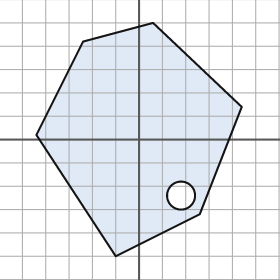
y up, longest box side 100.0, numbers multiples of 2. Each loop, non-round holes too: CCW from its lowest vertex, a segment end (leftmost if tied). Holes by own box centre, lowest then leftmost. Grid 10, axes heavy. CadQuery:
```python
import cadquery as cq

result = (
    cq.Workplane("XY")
    .moveTo(-10.0, -50.0)
    .lineTo(26.0, -32.0)
    .lineTo(44.0, 14.0)
    .lineTo(6.0, 50.0)
    .lineTo(-24.0, 42.0)
    .lineTo(-44.0, 2.0)
    .close()
    .moveTo(18.0, -24.0)
    .circle(6.0)
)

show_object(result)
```